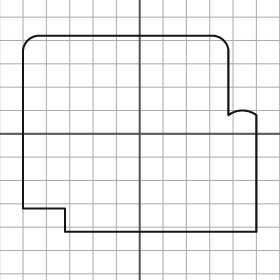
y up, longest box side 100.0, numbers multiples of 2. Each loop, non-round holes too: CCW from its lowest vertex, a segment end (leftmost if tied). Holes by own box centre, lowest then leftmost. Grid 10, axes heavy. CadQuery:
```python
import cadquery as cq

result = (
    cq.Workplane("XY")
    .moveTo(-32.0, -42.0)
    .lineTo(50.0, -42.0)
    .lineTo(50.0, 8.0)
    .threePointArc((44.0, 10.0), (38.0, 8.0))
    .lineTo(38.0, 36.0)
    .threePointArc((36.0, 40.0), (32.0, 42.0))
    .lineTo(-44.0, 42.0)
    .threePointArc((-48.0, 40.0), (-50.0, 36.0))
    .lineTo(-50.0, -32.0)
    .lineTo(-32.0, -32.0)
    .close()
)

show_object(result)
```